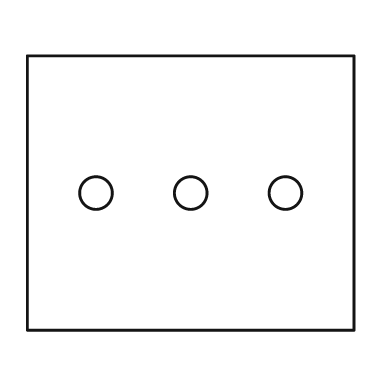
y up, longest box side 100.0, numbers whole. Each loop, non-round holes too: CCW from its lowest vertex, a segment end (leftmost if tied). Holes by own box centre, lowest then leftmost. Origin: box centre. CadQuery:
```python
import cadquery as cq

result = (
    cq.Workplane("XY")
    .moveTo(-50.0, -42.0)
    .lineTo(50.0, -42.0)
    .lineTo(50.0, 42.0)
    .lineTo(-50.0, 42.0)
    .close()
    .moveTo(-29.0, 0.0)
    .circle(5.0)
    .moveTo(0.0, 0.0)
    .circle(5.0)
    .moveTo(29.0, 0.0)
    .circle(5.0)
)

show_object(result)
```